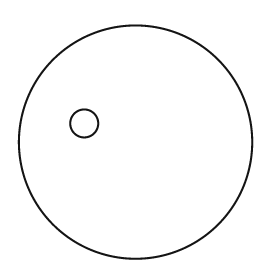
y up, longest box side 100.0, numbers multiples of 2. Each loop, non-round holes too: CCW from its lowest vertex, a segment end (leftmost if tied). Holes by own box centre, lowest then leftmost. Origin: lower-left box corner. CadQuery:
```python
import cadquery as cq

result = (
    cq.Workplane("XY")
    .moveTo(50.0, 50.0)
    .circle(50.0)
    .moveTo(28.0, 58.0)
    .circle(6.0)
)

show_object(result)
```